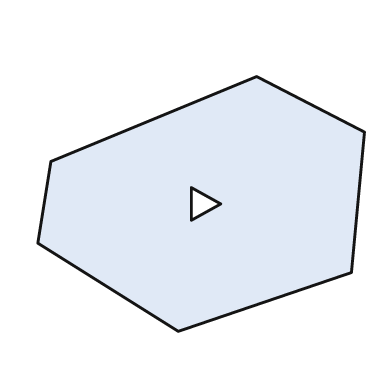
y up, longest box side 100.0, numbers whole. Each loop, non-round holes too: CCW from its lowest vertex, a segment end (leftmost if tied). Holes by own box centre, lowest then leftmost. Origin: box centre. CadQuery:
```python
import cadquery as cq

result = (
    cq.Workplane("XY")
    .moveTo(-7.0, -39.0)
    .lineTo(46.0, -21.0)
    .lineTo(50.0, 22.0)
    .lineTo(17.0, 39.0)
    .lineTo(-46.0, 13.0)
    .lineTo(-50.0, -12.0)
    .close()
    .moveTo(-3.0, -5.0)
    .lineTo(6.0, 0.0)
    .lineTo(-3.0, 5.0)
    .close()
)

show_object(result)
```